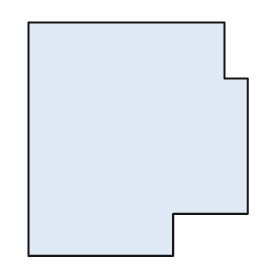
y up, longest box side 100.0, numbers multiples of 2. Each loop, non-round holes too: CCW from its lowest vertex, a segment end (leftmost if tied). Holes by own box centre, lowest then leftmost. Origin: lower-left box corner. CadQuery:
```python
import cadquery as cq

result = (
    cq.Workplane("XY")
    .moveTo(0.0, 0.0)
    .lineTo(62.0, 0.0)
    .lineTo(62.0, 18.0)
    .lineTo(94.0, 18.0)
    .lineTo(94.0, 76.0)
    .lineTo(84.0, 76.0)
    .lineTo(84.0, 100.0)
    .lineTo(0.0, 100.0)
    .close()
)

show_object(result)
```